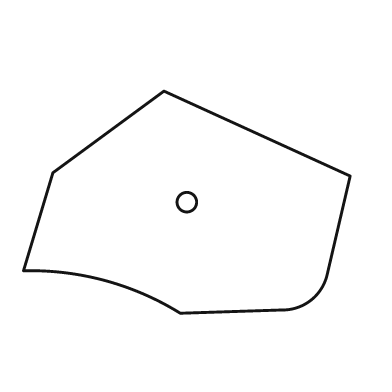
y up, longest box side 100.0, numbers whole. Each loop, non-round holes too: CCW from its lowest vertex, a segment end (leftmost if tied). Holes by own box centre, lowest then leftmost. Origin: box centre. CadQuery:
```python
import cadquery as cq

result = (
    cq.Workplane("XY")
    .moveTo(-2.0, -34.0)
    .lineTo(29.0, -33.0)
    .threePointArc((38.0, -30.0), (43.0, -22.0))
    .lineTo(50.0, 8.0)
    .lineTo(-7.0, 34.0)
    .lineTo(-41.0, 9.0)
    .lineTo(-50.0, -21.0)
    .threePointArc((-25.0, -24.0), (-2.0, -34.0))
    .close()
    .moveTo(0.0, 0.0)
    .circle(3.0)
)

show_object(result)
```